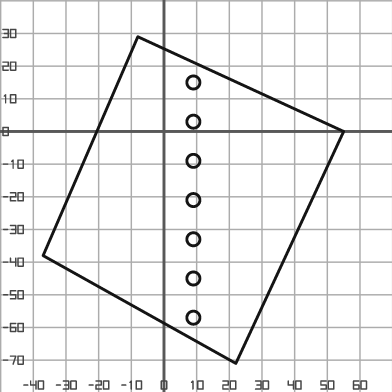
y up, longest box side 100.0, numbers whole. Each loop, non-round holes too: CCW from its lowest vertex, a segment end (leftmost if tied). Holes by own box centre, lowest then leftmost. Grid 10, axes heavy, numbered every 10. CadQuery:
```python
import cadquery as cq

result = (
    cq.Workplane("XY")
    .moveTo(22.0, -71.0)
    .lineTo(55.0, 0.0)
    .lineTo(-8.0, 29.0)
    .lineTo(-37.0, -38.0)
    .close()
    .moveTo(9.0, -57.0)
    .circle(2.0)
    .moveTo(9.0, -45.0)
    .circle(2.0)
    .moveTo(9.0, -33.0)
    .circle(2.0)
    .moveTo(9.0, -21.0)
    .circle(2.0)
    .moveTo(9.0, -9.0)
    .circle(2.0)
    .moveTo(9.0, 3.0)
    .circle(2.0)
    .moveTo(9.0, 15.0)
    .circle(2.0)
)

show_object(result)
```